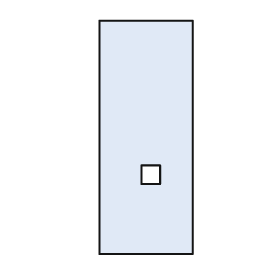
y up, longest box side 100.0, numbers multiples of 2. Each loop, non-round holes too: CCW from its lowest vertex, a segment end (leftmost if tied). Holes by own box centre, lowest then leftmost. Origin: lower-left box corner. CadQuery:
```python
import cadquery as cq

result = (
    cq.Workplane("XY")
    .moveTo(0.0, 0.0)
    .lineTo(40.0, 0.0)
    .lineTo(40.0, 100.0)
    .lineTo(0.0, 100.0)
    .close()
    .moveTo(18.0, 30.0)
    .lineTo(26.0, 30.0)
    .lineTo(26.0, 38.0)
    .lineTo(18.0, 38.0)
    .close()
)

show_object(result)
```